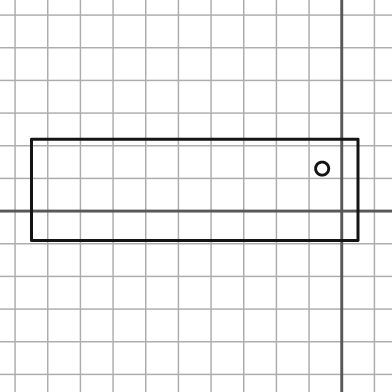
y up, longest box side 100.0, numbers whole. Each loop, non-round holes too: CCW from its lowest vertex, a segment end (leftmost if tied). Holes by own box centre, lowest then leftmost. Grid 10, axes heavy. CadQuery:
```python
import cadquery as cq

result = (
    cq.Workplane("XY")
    .moveTo(-95.0, -9.0)
    .lineTo(5.0, -9.0)
    .lineTo(5.0, 22.0)
    .lineTo(-95.0, 22.0)
    .close()
    .moveTo(-6.0, 13.0)
    .circle(2.0)
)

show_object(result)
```